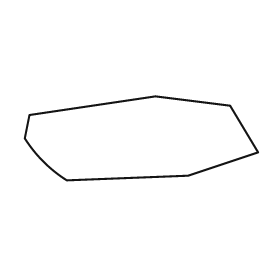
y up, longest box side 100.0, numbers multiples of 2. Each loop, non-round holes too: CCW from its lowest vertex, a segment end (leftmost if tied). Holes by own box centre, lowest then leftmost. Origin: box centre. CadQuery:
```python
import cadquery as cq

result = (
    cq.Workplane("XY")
    .moveTo(-32.0, -18.0)
    .lineTo(20.0, -16.0)
    .lineTo(50.0, -6.0)
    .lineTo(38.0, 14.0)
    .lineTo(6.0, 18.0)
    .lineTo(-48.0, 10.0)
    .lineTo(-50.0, 0.0)
    .threePointArc((-42.0, -10.0), (-32.0, -18.0))
    .close()
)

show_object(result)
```